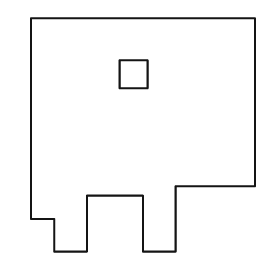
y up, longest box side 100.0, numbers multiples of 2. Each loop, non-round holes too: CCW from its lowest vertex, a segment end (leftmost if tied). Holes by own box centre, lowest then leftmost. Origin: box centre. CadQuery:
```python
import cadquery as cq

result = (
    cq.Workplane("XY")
    .moveTo(-38.0, -50.0)
    .lineTo(-24.0, -50.0)
    .lineTo(-24.0, -26.0)
    .lineTo(0.0, -26.0)
    .lineTo(0.0, -50.0)
    .lineTo(14.0, -50.0)
    .lineTo(14.0, -22.0)
    .lineTo(48.0, -22.0)
    .lineTo(48.0, 50.0)
    .lineTo(-48.0, 50.0)
    .lineTo(-48.0, -36.0)
    .lineTo(-38.0, -36.0)
    .close()
    .moveTo(-10.0, 20.0)
    .lineTo(2.0, 20.0)
    .lineTo(2.0, 32.0)
    .lineTo(-10.0, 32.0)
    .close()
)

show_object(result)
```